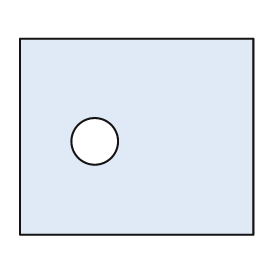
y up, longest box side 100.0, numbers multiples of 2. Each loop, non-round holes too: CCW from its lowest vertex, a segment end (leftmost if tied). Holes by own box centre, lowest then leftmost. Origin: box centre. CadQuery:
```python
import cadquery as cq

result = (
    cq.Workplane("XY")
    .moveTo(-50.0, -42.0)
    .lineTo(50.0, -42.0)
    .lineTo(50.0, 42.0)
    .lineTo(-50.0, 42.0)
    .close()
    .moveTo(-18.0, -2.0)
    .circle(10.0)
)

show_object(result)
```